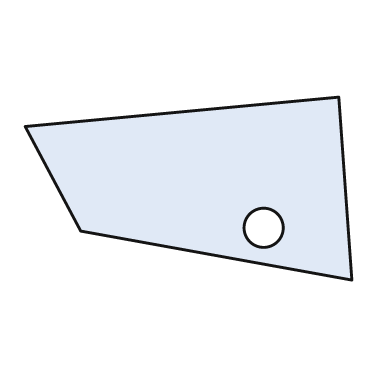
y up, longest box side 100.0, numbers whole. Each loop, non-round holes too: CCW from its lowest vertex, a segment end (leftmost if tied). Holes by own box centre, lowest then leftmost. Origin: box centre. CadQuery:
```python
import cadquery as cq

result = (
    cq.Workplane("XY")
    .moveTo(50.0, -28.0)
    .lineTo(46.0, 28.0)
    .lineTo(-50.0, 19.0)
    .lineTo(-33.0, -13.0)
    .close()
    .moveTo(23.0, -12.0)
    .circle(6.0)
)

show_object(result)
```